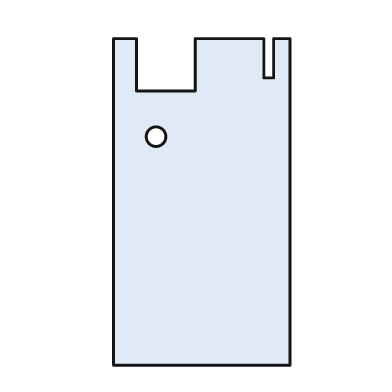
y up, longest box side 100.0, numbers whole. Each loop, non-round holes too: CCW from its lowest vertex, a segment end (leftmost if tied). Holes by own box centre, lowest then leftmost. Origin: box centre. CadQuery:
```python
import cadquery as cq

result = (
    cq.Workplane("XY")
    .moveTo(-27.0, -50.0)
    .lineTo(27.0, -50.0)
    .lineTo(27.0, 50.0)
    .lineTo(22.0, 50.0)
    .lineTo(22.0, 38.0)
    .lineTo(19.0, 38.0)
    .lineTo(19.0, 50.0)
    .lineTo(-2.0, 50.0)
    .lineTo(-2.0, 34.0)
    .lineTo(-20.0, 34.0)
    .lineTo(-20.0, 50.0)
    .lineTo(-27.0, 50.0)
    .close()
    .moveTo(-14.0, 20.0)
    .circle(3.0)
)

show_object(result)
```